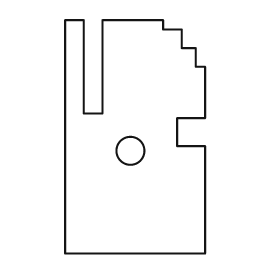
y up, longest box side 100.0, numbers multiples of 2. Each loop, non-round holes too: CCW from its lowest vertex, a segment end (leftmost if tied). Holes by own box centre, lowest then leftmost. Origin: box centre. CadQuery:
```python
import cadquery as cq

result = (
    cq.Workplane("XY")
    .moveTo(-30.0, -50.0)
    .lineTo(30.0, -50.0)
    .lineTo(30.0, -4.0)
    .lineTo(18.0, -4.0)
    .lineTo(18.0, 8.0)
    .lineTo(30.0, 8.0)
    .lineTo(30.0, 30.0)
    .lineTo(26.0, 30.0)
    .lineTo(26.0, 38.0)
    .lineTo(20.0, 38.0)
    .lineTo(20.0, 46.0)
    .lineTo(12.0, 46.0)
    .lineTo(12.0, 50.0)
    .lineTo(-14.0, 50.0)
    .lineTo(-14.0, 10.0)
    .lineTo(-22.0, 10.0)
    .lineTo(-22.0, 50.0)
    .lineTo(-30.0, 50.0)
    .close()
    .moveTo(-2.0, -6.0)
    .circle(6.0)
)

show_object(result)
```